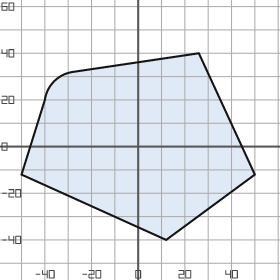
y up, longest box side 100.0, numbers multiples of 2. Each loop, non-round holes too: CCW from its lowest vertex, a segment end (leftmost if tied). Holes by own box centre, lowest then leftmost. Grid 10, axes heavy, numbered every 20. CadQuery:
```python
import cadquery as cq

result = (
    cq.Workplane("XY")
    .moveTo(12.0, -40.0)
    .lineTo(50.0, -12.0)
    .lineTo(26.0, 40.0)
    .lineTo(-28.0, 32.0)
    .threePointArc((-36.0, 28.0), (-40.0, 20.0))
    .lineTo(-50.0, -12.0)
    .close()
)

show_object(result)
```